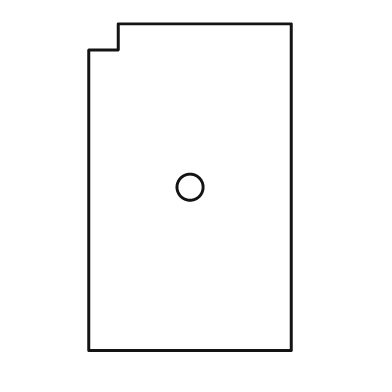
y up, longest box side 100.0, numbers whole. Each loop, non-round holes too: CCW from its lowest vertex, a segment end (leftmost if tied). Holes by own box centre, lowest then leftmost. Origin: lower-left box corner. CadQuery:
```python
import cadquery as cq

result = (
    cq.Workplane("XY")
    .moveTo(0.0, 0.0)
    .lineTo(62.0, 0.0)
    .lineTo(62.0, 100.0)
    .lineTo(9.0, 100.0)
    .lineTo(9.0, 92.0)
    .lineTo(0.0, 92.0)
    .close()
    .moveTo(31.0, 50.0)
    .circle(4.0)
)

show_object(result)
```